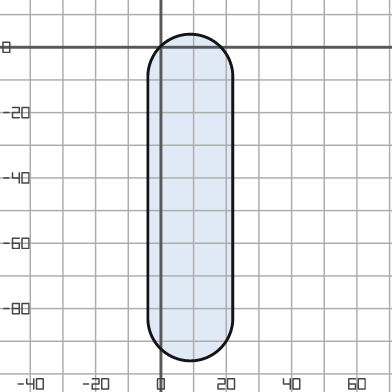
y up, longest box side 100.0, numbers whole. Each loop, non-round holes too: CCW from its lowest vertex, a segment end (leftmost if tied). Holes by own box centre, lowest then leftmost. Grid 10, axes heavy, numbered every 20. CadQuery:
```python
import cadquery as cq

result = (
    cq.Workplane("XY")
    .moveTo(-4.0, -83.0)
    .threePointArc((9.0, -96.0), (22.0, -83.0))
    .lineTo(22.0, -9.0)
    .threePointArc((9.0, 4.0), (-4.0, -9.0))
    .close()
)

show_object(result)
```